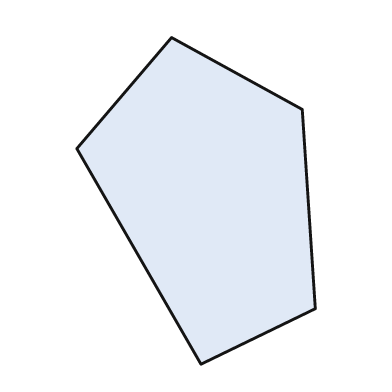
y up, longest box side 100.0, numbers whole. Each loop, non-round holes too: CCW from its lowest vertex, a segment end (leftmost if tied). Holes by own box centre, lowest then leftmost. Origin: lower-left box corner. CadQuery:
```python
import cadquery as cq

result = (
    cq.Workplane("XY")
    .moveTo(38.0, 0.0)
    .lineTo(73.0, 17.0)
    .lineTo(69.0, 78.0)
    .lineTo(29.0, 100.0)
    .lineTo(0.0, 66.0)
    .close()
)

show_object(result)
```